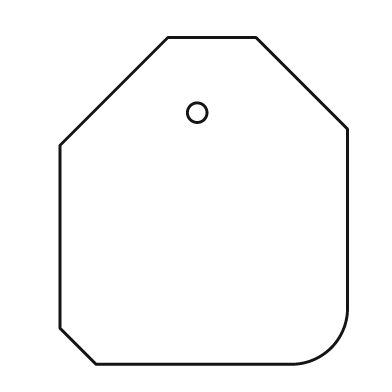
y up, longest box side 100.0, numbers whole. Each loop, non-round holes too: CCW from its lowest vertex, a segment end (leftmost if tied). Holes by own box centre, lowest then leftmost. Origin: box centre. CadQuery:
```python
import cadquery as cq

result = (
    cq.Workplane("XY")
    .moveTo(-33.0, -50.0)
    .lineTo(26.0, -50.0)
    .threePointArc((39.0, -45.0), (44.0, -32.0))
    .lineTo(44.0, 22.0)
    .lineTo(16.0, 50.0)
    .lineTo(-11.0, 50.0)
    .lineTo(-44.0, 17.0)
    .lineTo(-44.0, -39.0)
    .close()
    .moveTo(-2.0, 27.0)
    .circle(3.0)
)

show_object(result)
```